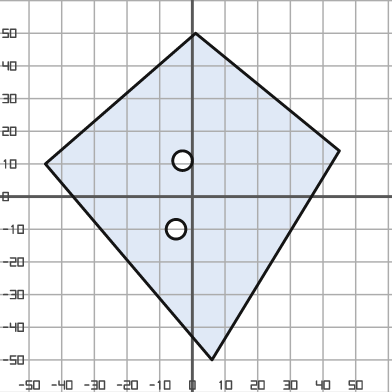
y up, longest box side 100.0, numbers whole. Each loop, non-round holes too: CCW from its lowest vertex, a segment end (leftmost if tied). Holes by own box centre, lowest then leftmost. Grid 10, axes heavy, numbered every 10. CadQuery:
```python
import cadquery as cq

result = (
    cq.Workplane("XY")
    .moveTo(6.0, -50.0)
    .lineTo(45.0, 14.0)
    .lineTo(1.0, 50.0)
    .lineTo(-45.0, 10.0)
    .close()
    .moveTo(-5.0, -10.0)
    .circle(3.0)
    .moveTo(-3.0, 11.0)
    .circle(3.0)
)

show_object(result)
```